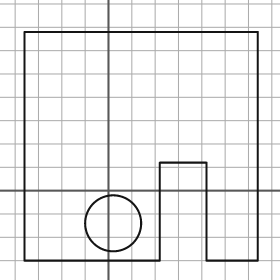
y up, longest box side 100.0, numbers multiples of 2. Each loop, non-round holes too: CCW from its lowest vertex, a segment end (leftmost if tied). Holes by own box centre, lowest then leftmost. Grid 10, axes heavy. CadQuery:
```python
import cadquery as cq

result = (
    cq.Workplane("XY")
    .moveTo(-36.0, -30.0)
    .lineTo(22.0, -30.0)
    .lineTo(22.0, 12.0)
    .lineTo(42.0, 12.0)
    .lineTo(42.0, -30.0)
    .lineTo(64.0, -30.0)
    .lineTo(64.0, 68.0)
    .lineTo(-36.0, 68.0)
    .close()
    .moveTo(2.0, -14.0)
    .circle(12.0)
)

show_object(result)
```